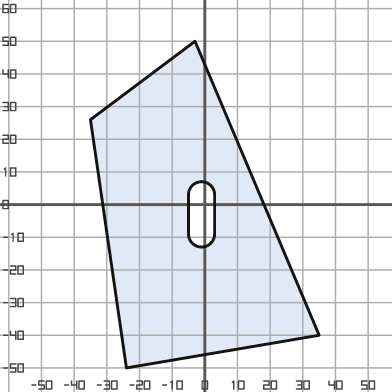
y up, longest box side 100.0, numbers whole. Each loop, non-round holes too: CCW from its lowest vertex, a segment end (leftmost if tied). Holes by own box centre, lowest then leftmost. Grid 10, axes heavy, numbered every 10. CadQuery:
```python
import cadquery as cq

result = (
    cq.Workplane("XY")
    .moveTo(-24.0, -50.0)
    .lineTo(35.0, -40.0)
    .lineTo(-3.0, 50.0)
    .lineTo(-35.0, 26.0)
    .close()
    .moveTo(-5.0, -9.0)
    .threePointArc((-1.0, -13.0), (3.0, -9.0))
    .lineTo(3.0, 3.0)
    .threePointArc((-1.0, 7.0), (-5.0, 3.0))
    .close()
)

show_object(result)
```